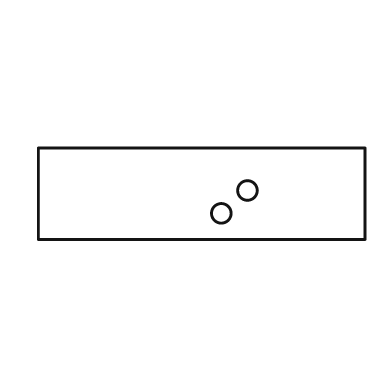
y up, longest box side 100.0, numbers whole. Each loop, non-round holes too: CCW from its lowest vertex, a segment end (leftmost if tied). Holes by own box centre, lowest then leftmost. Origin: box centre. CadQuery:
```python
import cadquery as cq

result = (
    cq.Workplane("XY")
    .moveTo(-50.0, -14.0)
    .lineTo(50.0, -14.0)
    .lineTo(50.0, 14.0)
    .lineTo(-50.0, 14.0)
    .close()
    .moveTo(6.0, -6.0)
    .circle(3.0)
    .moveTo(14.0, 1.0)
    .circle(3.0)
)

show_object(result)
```